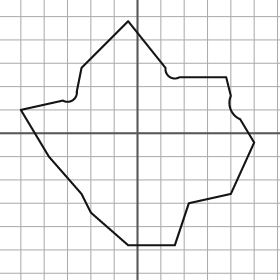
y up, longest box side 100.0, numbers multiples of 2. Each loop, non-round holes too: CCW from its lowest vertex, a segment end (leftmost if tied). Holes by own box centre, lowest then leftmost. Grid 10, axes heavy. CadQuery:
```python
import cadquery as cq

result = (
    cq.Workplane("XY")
    .moveTo(-4.0, -48.0)
    .lineTo(16.0, -48.0)
    .lineTo(22.0, -30.0)
    .lineTo(40.0, -26.0)
    .lineTo(50.0, -4.0)
    .lineTo(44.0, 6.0)
    .threePointArc((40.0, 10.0), (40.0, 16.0))
    .lineTo(38.0, 24.0)
    .lineTo(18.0, 24.0)
    .threePointArc((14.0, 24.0), (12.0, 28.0))
    .lineTo(-4.0, 48.0)
    .lineTo(-24.0, 28.0)
    .lineTo(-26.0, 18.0)
    .threePointArc((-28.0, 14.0), (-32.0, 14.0))
    .lineTo(-50.0, 10.0)
    .lineTo(-38.0, -10.0)
    .lineTo(-24.0, -26.0)
    .lineTo(-20.0, -34.0)
    .close()
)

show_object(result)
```